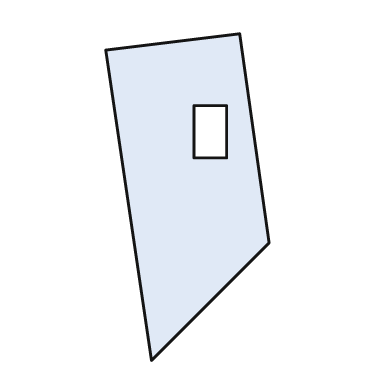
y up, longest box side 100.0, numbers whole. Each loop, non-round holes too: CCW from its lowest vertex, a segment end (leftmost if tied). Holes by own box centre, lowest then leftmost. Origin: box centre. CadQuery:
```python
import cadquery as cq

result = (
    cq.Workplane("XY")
    .moveTo(-11.0, -50.0)
    .lineTo(25.0, -14.0)
    .lineTo(16.0, 50.0)
    .lineTo(-25.0, 45.0)
    .close()
    .moveTo(2.0, 12.0)
    .lineTo(12.0, 12.0)
    .lineTo(12.0, 28.0)
    .lineTo(2.0, 28.0)
    .close()
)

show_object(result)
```